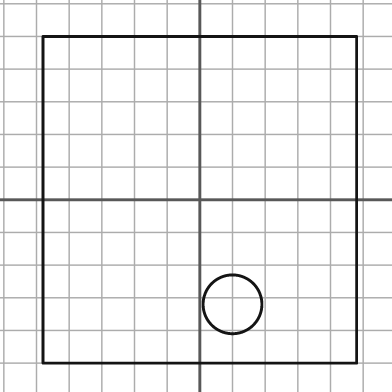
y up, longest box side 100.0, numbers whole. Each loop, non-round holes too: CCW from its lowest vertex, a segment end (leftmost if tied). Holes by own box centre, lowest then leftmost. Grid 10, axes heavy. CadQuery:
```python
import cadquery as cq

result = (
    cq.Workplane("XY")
    .moveTo(-48.0, -50.0)
    .lineTo(48.0, -50.0)
    .lineTo(48.0, 50.0)
    .lineTo(-48.0, 50.0)
    .close()
    .moveTo(10.0, -32.0)
    .circle(9.0)
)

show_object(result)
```